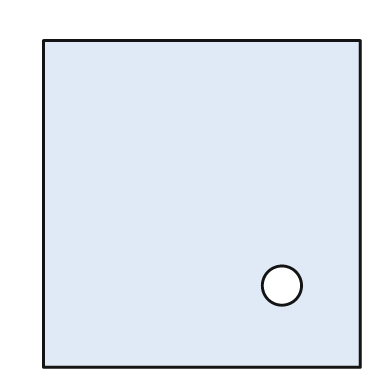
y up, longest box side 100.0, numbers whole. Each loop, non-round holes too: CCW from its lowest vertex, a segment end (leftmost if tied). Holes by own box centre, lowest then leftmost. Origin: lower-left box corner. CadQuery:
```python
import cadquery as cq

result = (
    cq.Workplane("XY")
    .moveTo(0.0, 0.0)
    .lineTo(97.0, 0.0)
    .lineTo(97.0, 100.0)
    .lineTo(0.0, 100.0)
    .close()
    .moveTo(73.0, 25.0)
    .circle(6.0)
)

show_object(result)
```